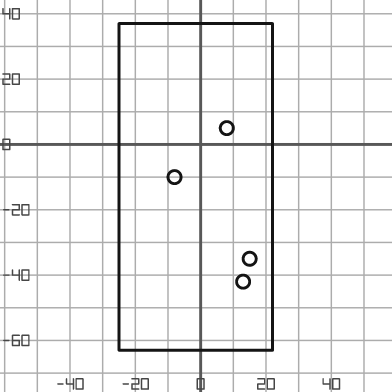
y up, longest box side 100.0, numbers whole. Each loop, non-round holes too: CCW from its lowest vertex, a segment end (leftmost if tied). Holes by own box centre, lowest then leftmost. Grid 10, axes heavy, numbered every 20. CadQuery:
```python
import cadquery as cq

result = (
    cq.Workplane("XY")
    .moveTo(-25.0, -63.0)
    .lineTo(22.0, -63.0)
    .lineTo(22.0, 37.0)
    .lineTo(-25.0, 37.0)
    .close()
    .moveTo(13.0, -42.0)
    .circle(2.0)
    .moveTo(15.0, -35.0)
    .circle(2.0)
    .moveTo(-8.0, -10.0)
    .circle(2.0)
    .moveTo(8.0, 5.0)
    .circle(2.0)
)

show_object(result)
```